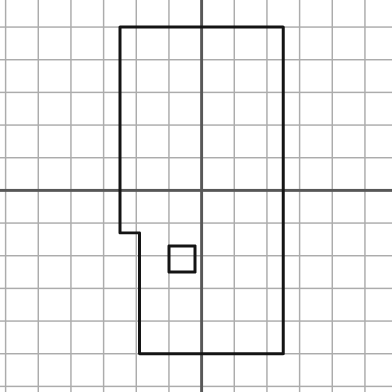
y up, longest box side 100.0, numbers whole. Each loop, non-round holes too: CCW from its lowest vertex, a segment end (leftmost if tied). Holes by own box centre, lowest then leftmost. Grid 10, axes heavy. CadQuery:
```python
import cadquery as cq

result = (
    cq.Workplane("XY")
    .moveTo(-19.0, -50.0)
    .lineTo(25.0, -50.0)
    .lineTo(25.0, 50.0)
    .lineTo(-25.0, 50.0)
    .lineTo(-25.0, -13.0)
    .lineTo(-19.0, -13.0)
    .close()
    .moveTo(-10.0, -25.0)
    .lineTo(-2.0, -25.0)
    .lineTo(-2.0, -17.0)
    .lineTo(-10.0, -17.0)
    .close()
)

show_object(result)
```